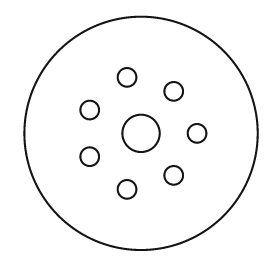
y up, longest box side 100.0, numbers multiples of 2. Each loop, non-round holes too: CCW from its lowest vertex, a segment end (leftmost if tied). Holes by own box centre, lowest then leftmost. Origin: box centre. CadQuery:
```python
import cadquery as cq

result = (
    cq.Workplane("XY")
    .moveTo(0.0, 0.0)
    .circle(50.0)
    .moveTo(-6.0, -24.0)
    .circle(4.0)
    .moveTo(14.0, -18.0)
    .circle(4.0)
    .moveTo(-22.0, -10.0)
    .circle(4.0)
    .moveTo(0.0, 0.0)
    .circle(8.0)
    .moveTo(24.0, 0.0)
    .circle(4.0)
    .moveTo(-22.0, 10.0)
    .circle(4.0)
    .moveTo(14.0, 18.0)
    .circle(4.0)
    .moveTo(-6.0, 24.0)
    .circle(4.0)
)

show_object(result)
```